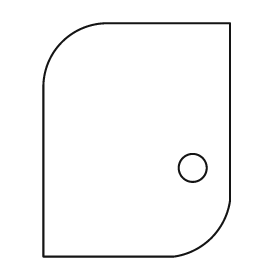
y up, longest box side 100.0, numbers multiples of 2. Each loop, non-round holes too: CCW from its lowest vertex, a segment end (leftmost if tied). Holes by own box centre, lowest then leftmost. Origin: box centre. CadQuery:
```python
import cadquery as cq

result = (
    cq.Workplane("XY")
    .moveTo(-40.0, -50.0)
    .lineTo(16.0, -50.0)
    .threePointArc((32.0, -42.0), (40.0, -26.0))
    .lineTo(40.0, 50.0)
    .lineTo(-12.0, 50.0)
    .threePointArc((-32.0, 42.0), (-40.0, 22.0))
    .close()
    .moveTo(24.0, -12.0)
    .circle(6.0)
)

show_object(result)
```